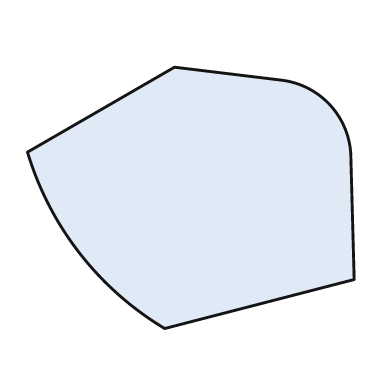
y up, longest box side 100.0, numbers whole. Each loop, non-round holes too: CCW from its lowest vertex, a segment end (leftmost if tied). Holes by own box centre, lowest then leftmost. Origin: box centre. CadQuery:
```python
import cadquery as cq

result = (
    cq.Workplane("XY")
    .moveTo(-8.0, -40.0)
    .lineTo(50.0, -25.0)
    .lineTo(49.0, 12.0)
    .threePointArc((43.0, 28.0), (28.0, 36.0))
    .lineTo(-5.0, 40.0)
    .lineTo(-50.0, 14.0)
    .threePointArc((-34.0, -17.0), (-8.0, -40.0))
    .close()
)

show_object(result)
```